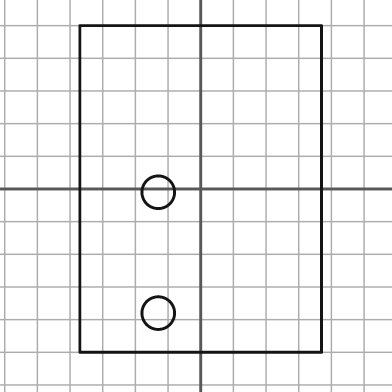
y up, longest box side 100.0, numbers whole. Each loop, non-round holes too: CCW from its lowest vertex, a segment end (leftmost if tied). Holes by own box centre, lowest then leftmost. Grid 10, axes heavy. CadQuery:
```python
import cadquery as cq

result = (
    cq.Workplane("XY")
    .moveTo(-37.0, -50.0)
    .lineTo(37.0, -50.0)
    .lineTo(37.0, 50.0)
    .lineTo(-37.0, 50.0)
    .close()
    .moveTo(-13.0, -38.0)
    .circle(5.0)
    .moveTo(-13.0, -1.0)
    .circle(5.0)
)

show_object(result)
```